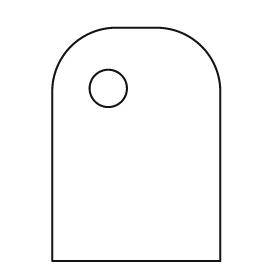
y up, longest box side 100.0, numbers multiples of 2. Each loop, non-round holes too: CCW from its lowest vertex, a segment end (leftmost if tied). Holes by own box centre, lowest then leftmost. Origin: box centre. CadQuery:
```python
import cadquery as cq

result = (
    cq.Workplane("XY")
    .moveTo(-36.0, -50.0)
    .lineTo(36.0, -50.0)
    .lineTo(36.0, 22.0)
    .threePointArc((28.0, 42.0), (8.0, 50.0))
    .lineTo(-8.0, 50.0)
    .threePointArc((-28.0, 42.0), (-36.0, 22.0))
    .close()
    .moveTo(-12.0, 24.0)
    .circle(8.0)
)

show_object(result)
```